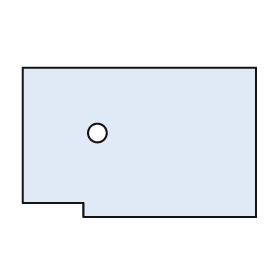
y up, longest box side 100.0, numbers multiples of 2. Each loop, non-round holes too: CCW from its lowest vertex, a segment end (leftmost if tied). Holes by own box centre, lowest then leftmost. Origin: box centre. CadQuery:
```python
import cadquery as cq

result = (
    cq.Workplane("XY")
    .moveTo(-24.0, -32.0)
    .lineTo(50.0, -32.0)
    .lineTo(50.0, 32.0)
    .lineTo(-50.0, 32.0)
    .lineTo(-50.0, -26.0)
    .lineTo(-24.0, -26.0)
    .close()
    .moveTo(-18.0, 4.0)
    .circle(4.0)
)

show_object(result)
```